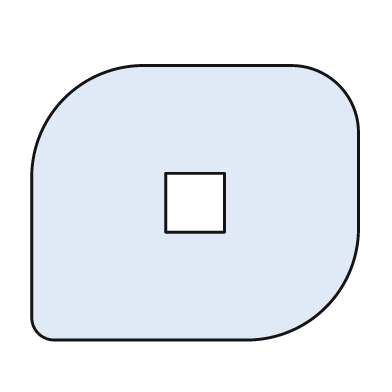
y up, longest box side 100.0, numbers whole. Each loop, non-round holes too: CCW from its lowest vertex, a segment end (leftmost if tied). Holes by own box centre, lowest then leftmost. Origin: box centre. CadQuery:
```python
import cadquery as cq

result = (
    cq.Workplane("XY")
    .moveTo(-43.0, -42.0)
    .lineTo(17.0, -42.0)
    .threePointArc((40.0, -32.0), (50.0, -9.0))
    .lineTo(50.0, 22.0)
    .threePointArc((44.0, 36.0), (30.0, 42.0))
    .lineTo(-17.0, 42.0)
    .threePointArc((-40.0, 32.0), (-50.0, 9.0))
    .lineTo(-50.0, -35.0)
    .threePointArc((-48.0, -40.0), (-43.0, -42.0))
    .close()
    .moveTo(-9.0, -9.0)
    .lineTo(9.0, -9.0)
    .lineTo(9.0, 9.0)
    .lineTo(-9.0, 9.0)
    .close()
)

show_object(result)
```